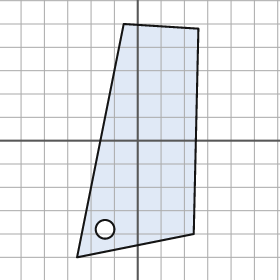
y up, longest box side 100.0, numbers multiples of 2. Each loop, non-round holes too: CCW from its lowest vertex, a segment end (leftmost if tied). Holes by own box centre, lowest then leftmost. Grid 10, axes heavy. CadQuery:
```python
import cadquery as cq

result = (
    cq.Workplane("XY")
    .moveTo(-26.0, -50.0)
    .lineTo(24.0, -40.0)
    .lineTo(26.0, 48.0)
    .lineTo(-6.0, 50.0)
    .close()
    .moveTo(-14.0, -38.0)
    .circle(4.0)
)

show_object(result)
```